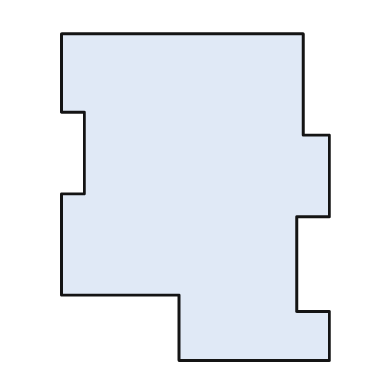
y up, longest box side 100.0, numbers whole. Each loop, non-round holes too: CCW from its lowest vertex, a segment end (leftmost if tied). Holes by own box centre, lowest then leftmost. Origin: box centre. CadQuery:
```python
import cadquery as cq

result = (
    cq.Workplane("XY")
    .moveTo(-5.0, -50.0)
    .lineTo(41.0, -50.0)
    .lineTo(41.0, -35.0)
    .lineTo(31.0, -35.0)
    .lineTo(31.0, -6.0)
    .lineTo(41.0, -6.0)
    .lineTo(41.0, 19.0)
    .lineTo(33.0, 19.0)
    .lineTo(33.0, 50.0)
    .lineTo(-41.0, 50.0)
    .lineTo(-41.0, 26.0)
    .lineTo(-34.0, 26.0)
    .lineTo(-34.0, 1.0)
    .lineTo(-41.0, 1.0)
    .lineTo(-41.0, -30.0)
    .lineTo(-5.0, -30.0)
    .close()
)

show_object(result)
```